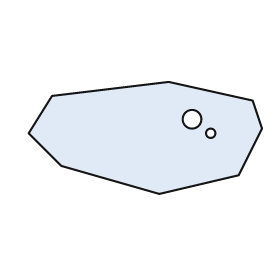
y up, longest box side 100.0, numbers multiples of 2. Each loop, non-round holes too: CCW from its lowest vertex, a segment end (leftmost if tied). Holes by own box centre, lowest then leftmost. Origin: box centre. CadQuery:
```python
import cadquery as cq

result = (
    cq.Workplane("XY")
    .moveTo(6.0, -24.0)
    .lineTo(40.0, -16.0)
    .lineTo(50.0, 4.0)
    .lineTo(46.0, 16.0)
    .lineTo(10.0, 24.0)
    .lineTo(-40.0, 18.0)
    .lineTo(-50.0, 2.0)
    .lineTo(-36.0, -12.0)
    .close()
    .moveTo(28.0, 2.0)
    .circle(2.0)
    .moveTo(20.0, 8.0)
    .circle(4.0)
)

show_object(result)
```